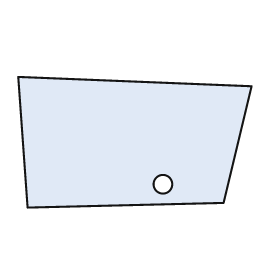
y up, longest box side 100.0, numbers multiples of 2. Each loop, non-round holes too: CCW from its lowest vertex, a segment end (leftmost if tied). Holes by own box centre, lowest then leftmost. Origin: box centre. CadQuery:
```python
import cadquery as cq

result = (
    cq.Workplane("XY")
    .moveTo(-46.0, -28.0)
    .lineTo(38.0, -26.0)
    .lineTo(50.0, 24.0)
    .lineTo(-50.0, 28.0)
    .close()
    .moveTo(12.0, -18.0)
    .circle(4.0)
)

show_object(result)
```